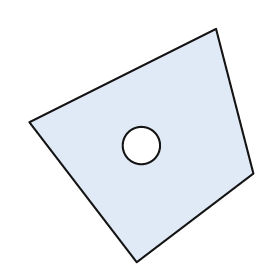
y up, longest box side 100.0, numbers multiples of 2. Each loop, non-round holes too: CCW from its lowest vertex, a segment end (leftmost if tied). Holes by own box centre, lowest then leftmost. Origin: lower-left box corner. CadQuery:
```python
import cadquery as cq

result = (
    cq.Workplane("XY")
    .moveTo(46.0, 0.0)
    .lineTo(96.0, 38.0)
    .lineTo(80.0, 100.0)
    .lineTo(0.0, 60.0)
    .close()
    .moveTo(48.0, 50.0)
    .circle(8.0)
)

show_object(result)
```